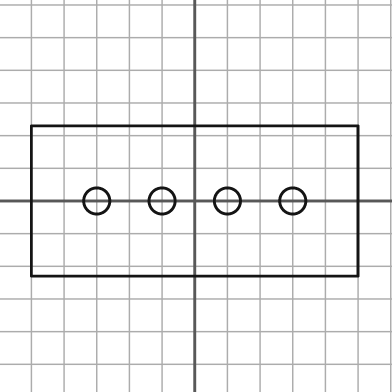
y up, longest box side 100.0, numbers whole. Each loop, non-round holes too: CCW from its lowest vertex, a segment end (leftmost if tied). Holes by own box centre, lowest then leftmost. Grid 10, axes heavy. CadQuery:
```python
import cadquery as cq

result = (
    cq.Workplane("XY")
    .moveTo(-50.0, -23.0)
    .lineTo(50.0, -23.0)
    .lineTo(50.0, 23.0)
    .lineTo(-50.0, 23.0)
    .close()
    .moveTo(-30.0, 0.0)
    .circle(4.0)
    .moveTo(-10.0, 0.0)
    .circle(4.0)
    .moveTo(10.0, 0.0)
    .circle(4.0)
    .moveTo(30.0, 0.0)
    .circle(4.0)
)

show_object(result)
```